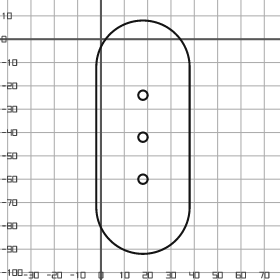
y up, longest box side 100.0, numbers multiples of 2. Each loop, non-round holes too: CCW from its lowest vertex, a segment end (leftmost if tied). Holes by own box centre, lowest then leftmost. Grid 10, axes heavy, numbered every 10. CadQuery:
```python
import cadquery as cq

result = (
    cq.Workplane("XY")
    .moveTo(-2.0, -72.0)
    .threePointArc((18.0, -92.0), (38.0, -72.0))
    .lineTo(38.0, -12.0)
    .threePointArc((18.0, 8.0), (-2.0, -12.0))
    .close()
    .moveTo(18.0, -60.0)
    .circle(2.0)
    .moveTo(18.0, -42.0)
    .circle(2.0)
    .moveTo(18.0, -24.0)
    .circle(2.0)
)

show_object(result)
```